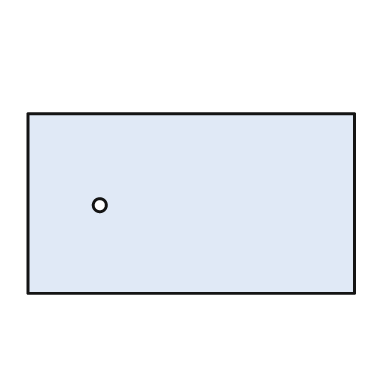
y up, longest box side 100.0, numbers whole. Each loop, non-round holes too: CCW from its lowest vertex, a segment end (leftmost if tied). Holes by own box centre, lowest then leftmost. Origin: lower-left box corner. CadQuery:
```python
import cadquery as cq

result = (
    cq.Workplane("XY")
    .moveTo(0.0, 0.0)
    .lineTo(100.0, 0.0)
    .lineTo(100.0, 55.0)
    .lineTo(0.0, 55.0)
    .close()
    .moveTo(22.0, 27.0)
    .circle(2.0)
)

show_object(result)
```